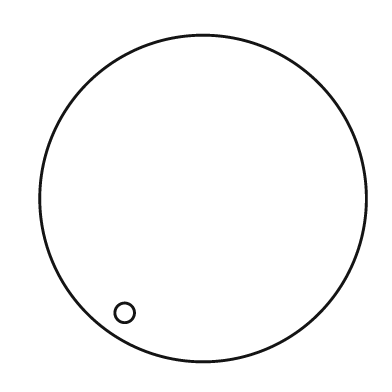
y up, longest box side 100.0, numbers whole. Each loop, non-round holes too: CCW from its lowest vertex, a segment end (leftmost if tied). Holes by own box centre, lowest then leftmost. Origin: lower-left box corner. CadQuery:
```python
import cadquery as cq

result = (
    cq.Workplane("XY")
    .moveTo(50.0, 50.0)
    .circle(50.0)
    .moveTo(26.0, 15.0)
    .circle(3.0)
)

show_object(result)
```